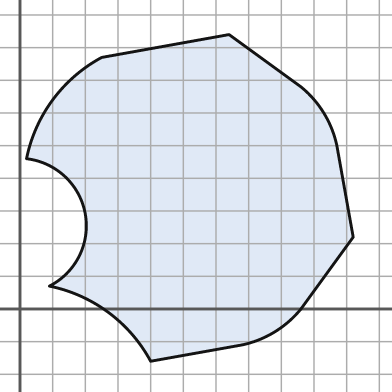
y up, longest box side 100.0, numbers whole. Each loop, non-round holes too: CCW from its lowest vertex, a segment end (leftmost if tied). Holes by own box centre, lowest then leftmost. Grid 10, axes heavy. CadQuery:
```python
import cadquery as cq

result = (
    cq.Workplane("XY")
    .moveTo(40.0, -16.0)
    .lineTo(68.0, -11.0)
    .threePointArc((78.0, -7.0), (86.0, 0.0))
    .lineTo(102.0, 22.0)
    .lineTo(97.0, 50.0)
    .threePointArc((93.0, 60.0), (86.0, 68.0))
    .lineTo(64.0, 84.0)
    .lineTo(25.0, 77.0)
    .threePointArc((10.0, 64.0), (2.0, 46.0))
    .threePointArc((20.0, 29.0), (9.0, 7.0))
    .threePointArc((27.0, -1.0), (40.0, -16.0))
    .close()
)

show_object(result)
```